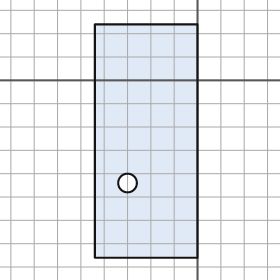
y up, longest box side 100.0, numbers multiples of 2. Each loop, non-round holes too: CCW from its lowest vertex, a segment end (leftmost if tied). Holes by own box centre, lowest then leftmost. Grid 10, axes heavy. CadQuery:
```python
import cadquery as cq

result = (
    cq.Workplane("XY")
    .moveTo(-44.0, -76.0)
    .lineTo(0.0, -76.0)
    .lineTo(0.0, 24.0)
    .lineTo(-44.0, 24.0)
    .close()
    .moveTo(-30.0, -44.0)
    .circle(4.0)
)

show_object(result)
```